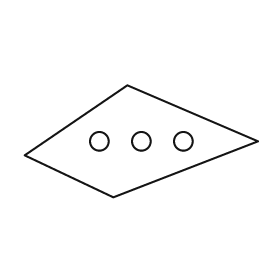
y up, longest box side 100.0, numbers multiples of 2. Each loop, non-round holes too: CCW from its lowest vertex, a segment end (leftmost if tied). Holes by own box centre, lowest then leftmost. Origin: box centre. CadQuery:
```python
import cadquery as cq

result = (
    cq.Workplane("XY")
    .moveTo(-12.0, -24.0)
    .lineTo(50.0, 0.0)
    .lineTo(-6.0, 24.0)
    .lineTo(-50.0, -6.0)
    .close()
    .moveTo(-18.0, 0.0)
    .circle(4.0)
    .moveTo(0.0, 0.0)
    .circle(4.0)
    .moveTo(18.0, 0.0)
    .circle(4.0)
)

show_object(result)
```